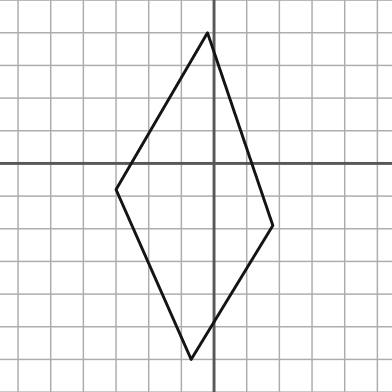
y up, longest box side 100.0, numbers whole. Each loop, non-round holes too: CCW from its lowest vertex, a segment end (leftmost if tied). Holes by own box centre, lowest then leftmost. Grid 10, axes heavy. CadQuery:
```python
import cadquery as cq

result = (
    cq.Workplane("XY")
    .moveTo(-7.0, -60.0)
    .lineTo(18.0, -19.0)
    .lineTo(-2.0, 40.0)
    .lineTo(-30.0, -8.0)
    .close()
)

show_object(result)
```